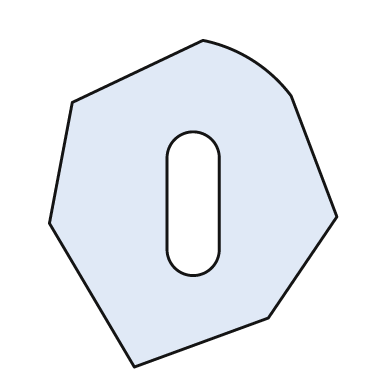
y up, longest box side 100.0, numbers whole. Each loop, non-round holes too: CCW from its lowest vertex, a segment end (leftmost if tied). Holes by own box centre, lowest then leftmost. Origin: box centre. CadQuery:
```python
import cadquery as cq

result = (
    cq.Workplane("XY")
    .moveTo(-18.0, -50.0)
    .lineTo(23.0, -35.0)
    .lineTo(44.0, -4.0)
    .lineTo(30.0, 33.0)
    .threePointArc((18.0, 44.0), (3.0, 50.0))
    .lineTo(-37.0, 31.0)
    .lineTo(-44.0, -6.0)
    .close()
    .moveTo(-8.0, -14.0)
    .threePointArc((0.0, -22.0), (8.0, -14.0))
    .lineTo(8.0, 14.0)
    .threePointArc((0.0, 22.0), (-8.0, 14.0))
    .close()
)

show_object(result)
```